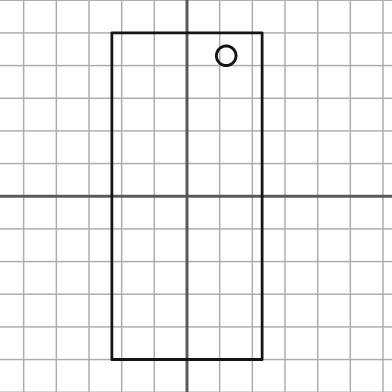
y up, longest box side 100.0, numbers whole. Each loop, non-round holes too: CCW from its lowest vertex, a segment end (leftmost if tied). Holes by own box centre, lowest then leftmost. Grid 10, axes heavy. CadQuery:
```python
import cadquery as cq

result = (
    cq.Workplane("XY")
    .moveTo(-23.0, -50.0)
    .lineTo(23.0, -50.0)
    .lineTo(23.0, 50.0)
    .lineTo(-23.0, 50.0)
    .close()
    .moveTo(12.0, 43.0)
    .circle(3.0)
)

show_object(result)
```